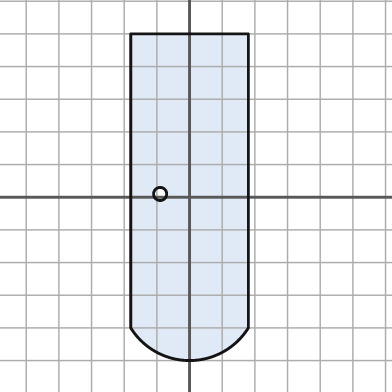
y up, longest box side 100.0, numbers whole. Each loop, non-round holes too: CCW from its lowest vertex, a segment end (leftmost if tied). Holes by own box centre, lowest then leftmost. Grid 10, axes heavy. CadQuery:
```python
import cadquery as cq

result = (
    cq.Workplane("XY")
    .moveTo(-18.0, -40.0)
    .threePointArc((0.0, -50.0), (18.0, -40.0))
    .lineTo(18.0, 50.0)
    .lineTo(-18.0, 50.0)
    .close()
    .moveTo(-9.0, 1.0)
    .circle(2.0)
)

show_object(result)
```